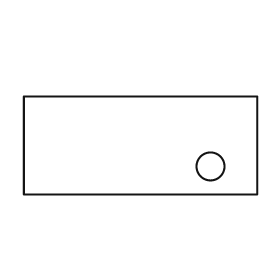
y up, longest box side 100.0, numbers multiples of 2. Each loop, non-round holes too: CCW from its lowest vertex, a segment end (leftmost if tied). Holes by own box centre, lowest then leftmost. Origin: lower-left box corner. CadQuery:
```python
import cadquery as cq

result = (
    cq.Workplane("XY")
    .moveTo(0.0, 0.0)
    .lineTo(100.0, 0.0)
    .lineTo(100.0, 42.0)
    .lineTo(0.0, 42.0)
    .close()
    .moveTo(80.0, 12.0)
    .circle(6.0)
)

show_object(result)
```